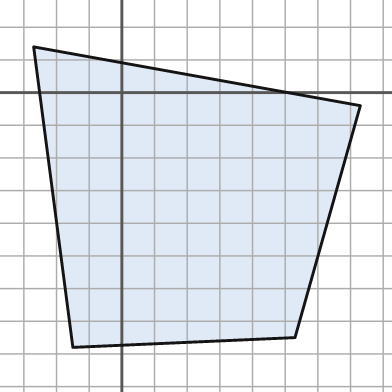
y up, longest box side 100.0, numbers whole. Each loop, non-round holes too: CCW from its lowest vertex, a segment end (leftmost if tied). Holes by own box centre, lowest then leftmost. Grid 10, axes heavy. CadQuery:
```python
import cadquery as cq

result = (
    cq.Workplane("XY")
    .moveTo(-15.0, -78.0)
    .lineTo(53.0, -75.0)
    .lineTo(73.0, -4.0)
    .lineTo(-27.0, 14.0)
    .close()
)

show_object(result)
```